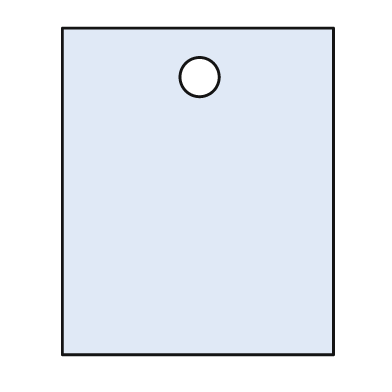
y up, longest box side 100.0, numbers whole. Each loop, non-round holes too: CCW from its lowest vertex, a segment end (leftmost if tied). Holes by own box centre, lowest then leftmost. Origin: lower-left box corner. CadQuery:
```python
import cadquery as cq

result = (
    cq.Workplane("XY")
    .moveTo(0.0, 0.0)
    .lineTo(83.0, 0.0)
    .lineTo(83.0, 100.0)
    .lineTo(0.0, 100.0)
    .close()
    .moveTo(42.0, 85.0)
    .circle(6.0)
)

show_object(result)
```